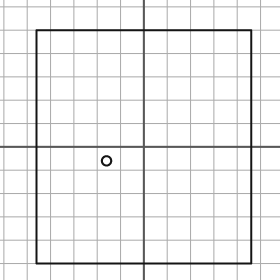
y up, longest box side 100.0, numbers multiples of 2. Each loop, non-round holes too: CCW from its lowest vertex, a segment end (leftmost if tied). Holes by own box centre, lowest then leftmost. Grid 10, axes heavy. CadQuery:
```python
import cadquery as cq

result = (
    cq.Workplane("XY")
    .moveTo(-46.0, -50.0)
    .lineTo(46.0, -50.0)
    .lineTo(46.0, 50.0)
    .lineTo(-46.0, 50.0)
    .close()
    .moveTo(-16.0, -6.0)
    .circle(2.0)
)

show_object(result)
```